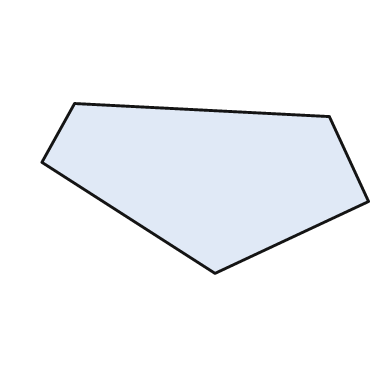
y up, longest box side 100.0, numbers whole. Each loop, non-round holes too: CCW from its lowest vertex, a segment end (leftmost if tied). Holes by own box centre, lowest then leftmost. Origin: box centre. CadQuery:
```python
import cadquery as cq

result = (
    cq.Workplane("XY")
    .moveTo(3.0, -26.0)
    .lineTo(50.0, -4.0)
    .lineTo(38.0, 22.0)
    .lineTo(-40.0, 26.0)
    .lineTo(-50.0, 8.0)
    .close()
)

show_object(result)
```